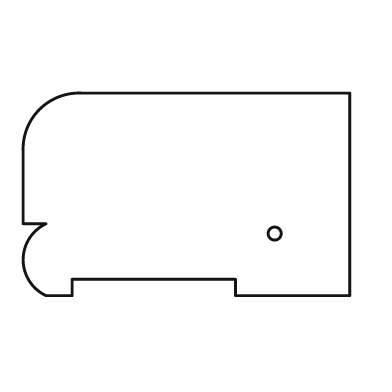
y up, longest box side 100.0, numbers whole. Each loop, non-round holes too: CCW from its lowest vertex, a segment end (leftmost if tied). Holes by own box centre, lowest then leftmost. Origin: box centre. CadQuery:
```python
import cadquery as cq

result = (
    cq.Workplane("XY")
    .moveTo(-43.0, -31.0)
    .lineTo(-35.0, -31.0)
    .lineTo(-35.0, -26.0)
    .lineTo(15.0, -26.0)
    .lineTo(15.0, -31.0)
    .lineTo(50.0, -31.0)
    .lineTo(50.0, 31.0)
    .lineTo(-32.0, 31.0)
    .threePointArc((-45.0, 26.0), (-50.0, 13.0))
    .lineTo(-50.0, -9.0)
    .lineTo(-43.0, -9.0)
    .threePointArc((-50.0, -20.0), (-43.0, -31.0))
    .close()
    .moveTo(27.0, -12.0)
    .circle(2.0)
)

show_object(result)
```